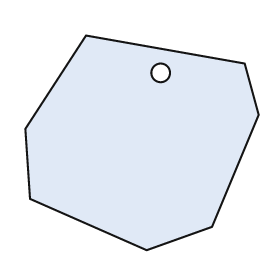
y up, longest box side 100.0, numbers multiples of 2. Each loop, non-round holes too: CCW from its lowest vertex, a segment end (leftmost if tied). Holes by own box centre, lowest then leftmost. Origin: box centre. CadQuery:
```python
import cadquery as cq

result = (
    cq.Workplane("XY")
    .moveTo(2.0, -46.0)
    .lineTo(30.0, -36.0)
    .lineTo(50.0, 12.0)
    .lineTo(44.0, 34.0)
    .lineTo(-24.0, 46.0)
    .lineTo(-50.0, 6.0)
    .lineTo(-48.0, -24.0)
    .close()
    .moveTo(8.0, 30.0)
    .circle(4.0)
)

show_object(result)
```